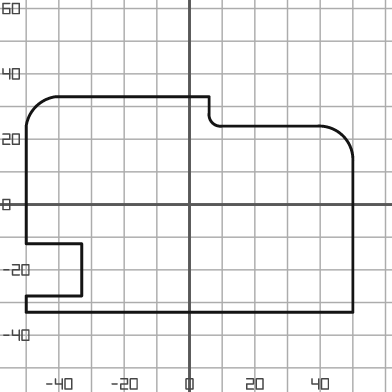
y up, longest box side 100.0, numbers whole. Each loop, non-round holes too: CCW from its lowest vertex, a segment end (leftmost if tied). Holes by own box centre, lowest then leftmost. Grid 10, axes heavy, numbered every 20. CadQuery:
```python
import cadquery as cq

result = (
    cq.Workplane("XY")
    .moveTo(-50.0, -33.0)
    .lineTo(50.0, -33.0)
    .lineTo(50.0, 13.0)
    .threePointArc((47.0, 21.0), (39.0, 24.0))
    .lineTo(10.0, 24.0)
    .threePointArc((7.0, 25.0), (6.0, 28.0))
    .lineTo(6.0, 33.0)
    .lineTo(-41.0, 33.0)
    .threePointArc((-47.0, 30.0), (-50.0, 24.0))
    .lineTo(-50.0, -12.0)
    .lineTo(-33.0, -12.0)
    .lineTo(-33.0, -28.0)
    .lineTo(-50.0, -28.0)
    .close()
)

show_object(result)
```